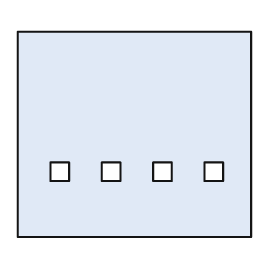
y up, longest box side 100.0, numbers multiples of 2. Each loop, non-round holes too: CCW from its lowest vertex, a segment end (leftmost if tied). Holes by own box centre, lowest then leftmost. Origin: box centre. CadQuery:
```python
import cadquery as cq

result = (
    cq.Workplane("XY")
    .moveTo(-50.0, -44.0)
    .lineTo(50.0, -44.0)
    .lineTo(50.0, 44.0)
    .lineTo(-50.0, 44.0)
    .close()
    .moveTo(-36.0, -20.0)
    .lineTo(-28.0, -20.0)
    .lineTo(-28.0, -12.0)
    .lineTo(-36.0, -12.0)
    .close()
    .moveTo(-14.0, -20.0)
    .lineTo(-6.0, -20.0)
    .lineTo(-6.0, -12.0)
    .lineTo(-14.0, -12.0)
    .close()
    .moveTo(8.0, -20.0)
    .lineTo(16.0, -20.0)
    .lineTo(16.0, -12.0)
    .lineTo(8.0, -12.0)
    .close()
    .moveTo(30.0, -20.0)
    .lineTo(38.0, -20.0)
    .lineTo(38.0, -12.0)
    .lineTo(30.0, -12.0)
    .close()
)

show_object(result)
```